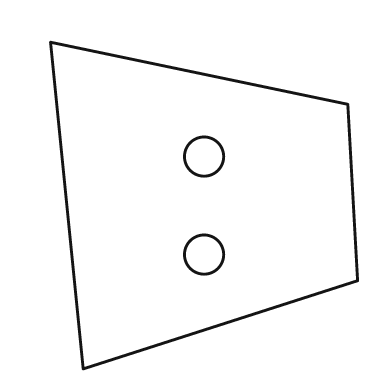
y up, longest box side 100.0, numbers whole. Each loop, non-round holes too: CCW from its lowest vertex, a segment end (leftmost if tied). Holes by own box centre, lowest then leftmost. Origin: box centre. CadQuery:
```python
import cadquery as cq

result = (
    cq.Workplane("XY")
    .moveTo(-37.0, -50.0)
    .lineTo(47.0, -23.0)
    .lineTo(44.0, 31.0)
    .lineTo(-47.0, 50.0)
    .close()
    .moveTo(0.0, -15.0)
    .circle(6.0)
    .moveTo(0.0, 15.0)
    .circle(6.0)
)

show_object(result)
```